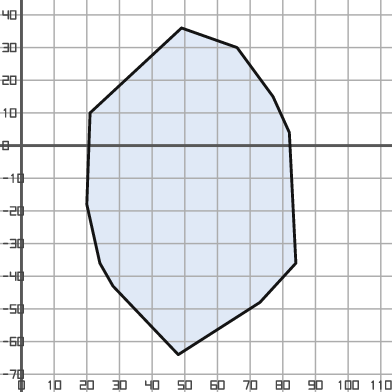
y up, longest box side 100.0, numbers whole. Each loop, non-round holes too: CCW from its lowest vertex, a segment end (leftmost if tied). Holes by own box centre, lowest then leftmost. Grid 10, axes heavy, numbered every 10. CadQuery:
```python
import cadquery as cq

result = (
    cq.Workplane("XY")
    .moveTo(48.0, -64.0)
    .lineTo(73.0, -48.0)
    .lineTo(84.0, -36.0)
    .lineTo(82.0, 4.0)
    .lineTo(77.0, 15.0)
    .lineTo(66.0, 30.0)
    .lineTo(49.0, 36.0)
    .lineTo(21.0, 10.0)
    .lineTo(20.0, -18.0)
    .lineTo(24.0, -36.0)
    .lineTo(28.0, -43.0)
    .close()
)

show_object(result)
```